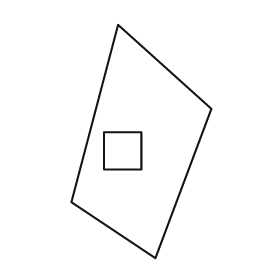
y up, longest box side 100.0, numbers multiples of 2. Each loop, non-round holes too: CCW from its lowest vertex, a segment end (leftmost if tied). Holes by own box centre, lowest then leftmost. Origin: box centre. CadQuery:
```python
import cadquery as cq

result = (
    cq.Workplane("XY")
    .moveTo(6.0, -50.0)
    .lineTo(30.0, 14.0)
    .lineTo(-10.0, 50.0)
    .lineTo(-30.0, -26.0)
    .close()
    .moveTo(-16.0, -12.0)
    .lineTo(0.0, -12.0)
    .lineTo(0.0, 4.0)
    .lineTo(-16.0, 4.0)
    .close()
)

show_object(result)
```